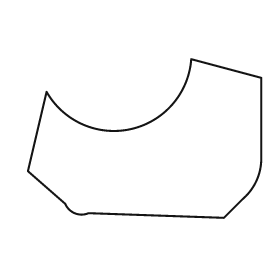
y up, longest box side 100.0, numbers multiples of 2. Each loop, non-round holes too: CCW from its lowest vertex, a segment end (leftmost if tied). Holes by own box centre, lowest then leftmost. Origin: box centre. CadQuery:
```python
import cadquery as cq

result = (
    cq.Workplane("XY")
    .moveTo(34.0, -34.0)
    .lineTo(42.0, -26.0)
    .threePointArc((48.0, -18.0), (50.0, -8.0))
    .lineTo(50.0, 26.0)
    .lineTo(20.0, 34.0)
    .threePointArc((-6.0, 4.0), (-42.0, 20.0))
    .lineTo(-50.0, -14.0)
    .lineTo(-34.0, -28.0)
    .threePointArc((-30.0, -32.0), (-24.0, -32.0))
    .close()
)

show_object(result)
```